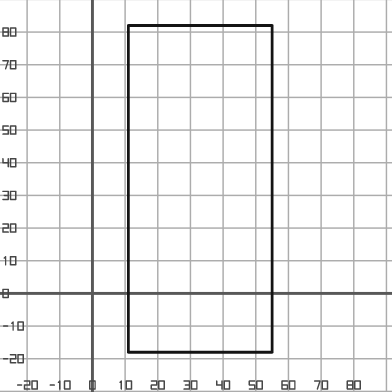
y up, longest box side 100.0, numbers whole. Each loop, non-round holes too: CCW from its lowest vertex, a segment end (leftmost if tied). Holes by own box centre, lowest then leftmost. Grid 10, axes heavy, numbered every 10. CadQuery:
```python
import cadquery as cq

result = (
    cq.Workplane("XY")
    .moveTo(11.0, -18.0)
    .lineTo(55.0, -18.0)
    .lineTo(55.0, 82.0)
    .lineTo(11.0, 82.0)
    .close()
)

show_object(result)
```